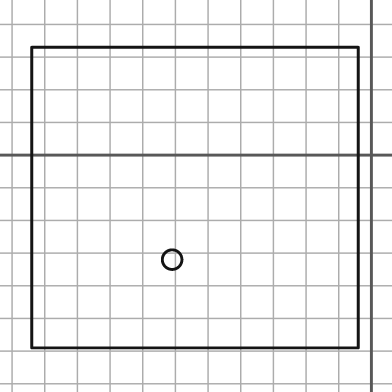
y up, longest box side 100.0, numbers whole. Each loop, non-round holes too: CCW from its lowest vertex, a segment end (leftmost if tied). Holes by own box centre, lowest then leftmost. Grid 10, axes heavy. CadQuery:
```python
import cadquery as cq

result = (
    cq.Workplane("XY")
    .moveTo(-104.0, -59.0)
    .lineTo(-4.0, -59.0)
    .lineTo(-4.0, 33.0)
    .lineTo(-104.0, 33.0)
    .close()
    .moveTo(-61.0, -32.0)
    .circle(3.0)
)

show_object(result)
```